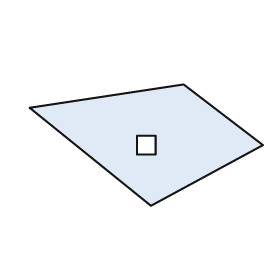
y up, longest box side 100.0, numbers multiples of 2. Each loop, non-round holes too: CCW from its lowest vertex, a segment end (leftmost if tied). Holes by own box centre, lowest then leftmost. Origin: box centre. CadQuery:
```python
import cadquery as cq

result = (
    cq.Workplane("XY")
    .moveTo(2.0, -26.0)
    .lineTo(50.0, 0.0)
    .lineTo(16.0, 26.0)
    .lineTo(-50.0, 16.0)
    .close()
    .moveTo(-4.0, -4.0)
    .lineTo(4.0, -4.0)
    .lineTo(4.0, 4.0)
    .lineTo(-4.0, 4.0)
    .close()
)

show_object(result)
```